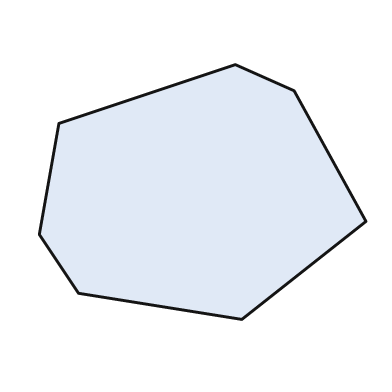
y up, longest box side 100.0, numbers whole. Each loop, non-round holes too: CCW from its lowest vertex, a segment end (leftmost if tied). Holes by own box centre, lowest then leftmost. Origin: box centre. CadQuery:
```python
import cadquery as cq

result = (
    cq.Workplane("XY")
    .moveTo(12.0, -39.0)
    .lineTo(50.0, -9.0)
    .lineTo(28.0, 31.0)
    .lineTo(10.0, 39.0)
    .lineTo(-44.0, 21.0)
    .lineTo(-50.0, -13.0)
    .lineTo(-38.0, -31.0)
    .close()
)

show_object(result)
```